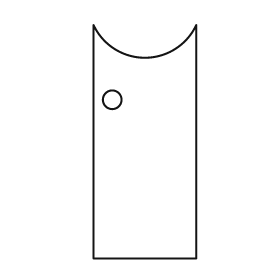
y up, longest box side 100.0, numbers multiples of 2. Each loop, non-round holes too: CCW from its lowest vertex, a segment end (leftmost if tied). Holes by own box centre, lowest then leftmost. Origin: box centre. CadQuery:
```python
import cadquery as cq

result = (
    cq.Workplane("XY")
    .moveTo(-22.0, -50.0)
    .lineTo(22.0, -50.0)
    .lineTo(22.0, 50.0)
    .threePointArc((0.0, 36.0), (-22.0, 50.0))
    .close()
    .moveTo(-14.0, 18.0)
    .circle(4.0)
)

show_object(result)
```